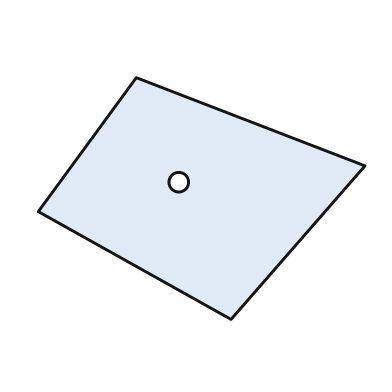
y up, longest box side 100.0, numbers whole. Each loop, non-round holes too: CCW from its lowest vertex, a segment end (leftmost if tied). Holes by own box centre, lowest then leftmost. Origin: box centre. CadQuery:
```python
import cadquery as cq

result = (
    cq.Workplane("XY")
    .moveTo(9.0, -37.0)
    .lineTo(50.0, 10.0)
    .lineTo(-20.0, 37.0)
    .lineTo(-50.0, -4.0)
    .close()
    .moveTo(-7.0, 5.0)
    .circle(3.0)
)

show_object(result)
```